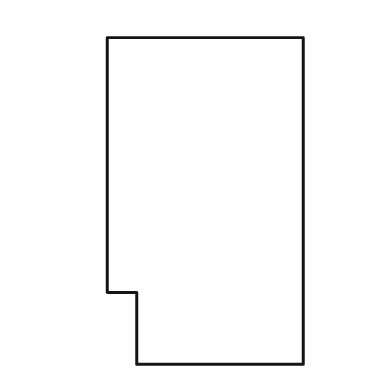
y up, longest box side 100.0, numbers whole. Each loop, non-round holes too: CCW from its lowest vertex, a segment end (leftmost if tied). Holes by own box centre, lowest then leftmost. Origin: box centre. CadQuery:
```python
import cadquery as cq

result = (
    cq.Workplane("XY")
    .moveTo(-21.0, -50.0)
    .lineTo(30.0, -50.0)
    .lineTo(30.0, 50.0)
    .lineTo(-30.0, 50.0)
    .lineTo(-30.0, -28.0)
    .lineTo(-21.0, -28.0)
    .close()
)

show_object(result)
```